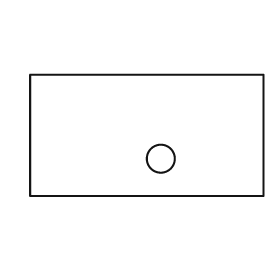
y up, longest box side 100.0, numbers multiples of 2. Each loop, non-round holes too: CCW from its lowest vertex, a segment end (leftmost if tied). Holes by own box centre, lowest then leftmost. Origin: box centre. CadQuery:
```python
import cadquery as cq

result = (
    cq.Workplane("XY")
    .moveTo(-50.0, -26.0)
    .lineTo(50.0, -26.0)
    .lineTo(50.0, 26.0)
    .lineTo(-50.0, 26.0)
    .close()
    .moveTo(6.0, -10.0)
    .circle(6.0)
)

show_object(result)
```